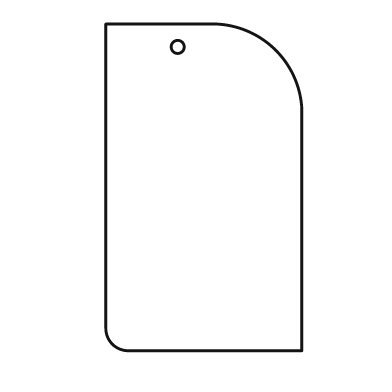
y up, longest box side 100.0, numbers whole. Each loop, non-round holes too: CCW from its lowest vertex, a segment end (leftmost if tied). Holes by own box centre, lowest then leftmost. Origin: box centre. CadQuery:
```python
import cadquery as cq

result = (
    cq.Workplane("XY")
    .moveTo(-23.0, -50.0)
    .lineTo(30.0, -50.0)
    .lineTo(30.0, 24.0)
    .threePointArc((22.0, 42.0), (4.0, 50.0))
    .lineTo(-30.0, 50.0)
    .lineTo(-30.0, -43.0)
    .threePointArc((-28.0, -48.0), (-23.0, -50.0))
    .close()
    .moveTo(-8.0, 43.0)
    .circle(2.0)
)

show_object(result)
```